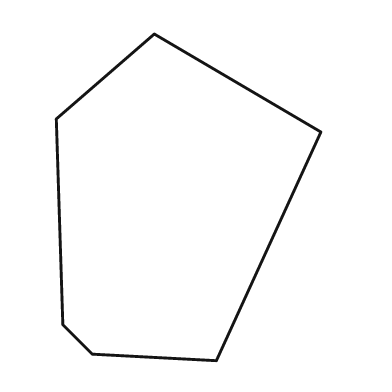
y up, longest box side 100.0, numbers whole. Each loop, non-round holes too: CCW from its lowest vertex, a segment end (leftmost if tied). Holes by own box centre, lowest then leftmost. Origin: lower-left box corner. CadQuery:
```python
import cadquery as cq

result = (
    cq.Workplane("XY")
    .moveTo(49.0, 0.0)
    .lineTo(81.0, 70.0)
    .lineTo(30.0, 100.0)
    .lineTo(0.0, 74.0)
    .lineTo(2.0, 11.0)
    .lineTo(11.0, 2.0)
    .close()
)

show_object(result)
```